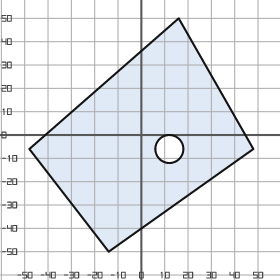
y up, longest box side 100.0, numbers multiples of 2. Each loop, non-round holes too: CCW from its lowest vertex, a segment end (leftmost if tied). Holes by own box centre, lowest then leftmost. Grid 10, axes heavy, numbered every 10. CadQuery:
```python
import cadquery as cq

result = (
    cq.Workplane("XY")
    .moveTo(-14.0, -50.0)
    .lineTo(48.0, -6.0)
    .lineTo(16.0, 50.0)
    .lineTo(-48.0, -6.0)
    .close()
    .moveTo(12.0, -6.0)
    .circle(6.0)
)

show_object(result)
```